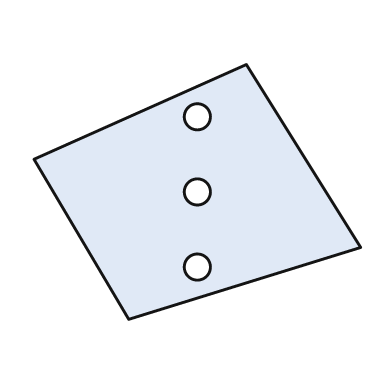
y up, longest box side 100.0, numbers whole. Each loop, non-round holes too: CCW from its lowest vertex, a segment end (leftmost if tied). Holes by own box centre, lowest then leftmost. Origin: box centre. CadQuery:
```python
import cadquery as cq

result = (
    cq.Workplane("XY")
    .moveTo(-21.0, -39.0)
    .lineTo(50.0, -17.0)
    .lineTo(15.0, 39.0)
    .lineTo(-50.0, 10.0)
    .close()
    .moveTo(0.0, -23.0)
    .circle(4.0)
    .moveTo(0.0, 0.0)
    .circle(4.0)
    .moveTo(0.0, 23.0)
    .circle(4.0)
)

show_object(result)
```